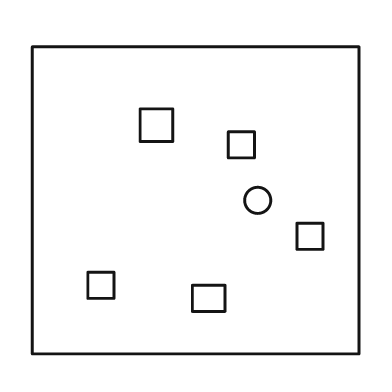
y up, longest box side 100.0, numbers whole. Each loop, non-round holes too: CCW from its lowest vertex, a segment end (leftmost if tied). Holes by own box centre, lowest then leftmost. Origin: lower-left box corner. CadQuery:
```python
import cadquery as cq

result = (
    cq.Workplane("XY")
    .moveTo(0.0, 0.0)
    .lineTo(100.0, 0.0)
    .lineTo(100.0, 94.0)
    .lineTo(0.0, 94.0)
    .close()
    .moveTo(49.0, 13.0)
    .lineTo(59.0, 13.0)
    .lineTo(59.0, 21.0)
    .lineTo(49.0, 21.0)
    .close()
    .moveTo(17.0, 17.0)
    .lineTo(25.0, 17.0)
    .lineTo(25.0, 25.0)
    .lineTo(17.0, 25.0)
    .close()
    .moveTo(81.0, 32.0)
    .lineTo(89.0, 32.0)
    .lineTo(89.0, 40.0)
    .lineTo(81.0, 40.0)
    .close()
    .moveTo(69.0, 47.0)
    .circle(4.0)
    .moveTo(60.0, 60.0)
    .lineTo(68.0, 60.0)
    .lineTo(68.0, 68.0)
    .lineTo(60.0, 68.0)
    .close()
    .moveTo(33.0, 65.0)
    .lineTo(43.0, 65.0)
    .lineTo(43.0, 75.0)
    .lineTo(33.0, 75.0)
    .close()
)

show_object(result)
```